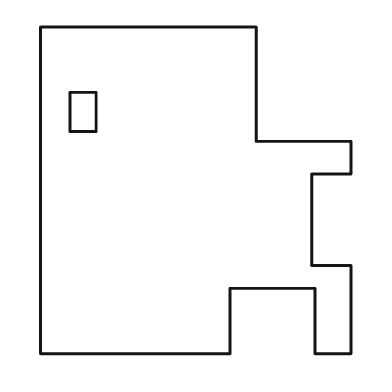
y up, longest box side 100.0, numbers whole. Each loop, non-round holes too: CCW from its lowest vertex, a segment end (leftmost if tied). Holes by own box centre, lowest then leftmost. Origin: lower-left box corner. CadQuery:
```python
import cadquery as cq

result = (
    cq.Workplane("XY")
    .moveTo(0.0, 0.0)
    .lineTo(58.0, 0.0)
    .lineTo(58.0, 20.0)
    .lineTo(84.0, 20.0)
    .lineTo(84.0, 0.0)
    .lineTo(95.0, 0.0)
    .lineTo(95.0, 27.0)
    .lineTo(83.0, 27.0)
    .lineTo(83.0, 55.0)
    .lineTo(95.0, 55.0)
    .lineTo(95.0, 65.0)
    .lineTo(66.0, 65.0)
    .lineTo(66.0, 100.0)
    .lineTo(0.0, 100.0)
    .close()
    .moveTo(9.0, 68.0)
    .lineTo(17.0, 68.0)
    .lineTo(17.0, 80.0)
    .lineTo(9.0, 80.0)
    .close()
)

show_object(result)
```